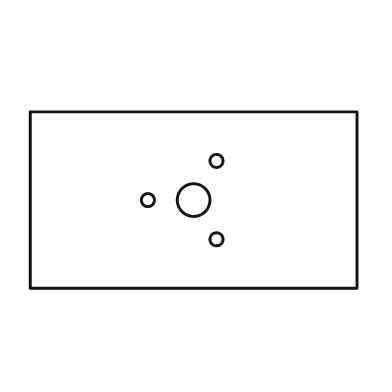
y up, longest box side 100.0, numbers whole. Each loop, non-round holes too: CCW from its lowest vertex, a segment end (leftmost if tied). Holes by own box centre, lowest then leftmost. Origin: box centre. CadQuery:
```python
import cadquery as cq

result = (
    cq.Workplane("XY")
    .moveTo(-50.0, -27.0)
    .lineTo(50.0, -27.0)
    .lineTo(50.0, 27.0)
    .lineTo(-50.0, 27.0)
    .close()
    .moveTo(7.0, -12.0)
    .circle(2.0)
    .moveTo(-14.0, 0.0)
    .circle(2.0)
    .moveTo(0.0, 0.0)
    .circle(5.0)
    .moveTo(7.0, 12.0)
    .circle(2.0)
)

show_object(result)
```